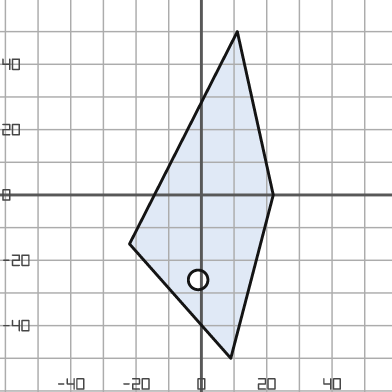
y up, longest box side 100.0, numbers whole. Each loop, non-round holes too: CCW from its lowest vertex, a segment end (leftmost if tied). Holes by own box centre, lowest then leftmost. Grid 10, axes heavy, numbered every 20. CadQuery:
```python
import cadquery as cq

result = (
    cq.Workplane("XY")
    .moveTo(9.0, -50.0)
    .lineTo(22.0, 0.0)
    .lineTo(11.0, 50.0)
    .lineTo(-22.0, -15.0)
    .close()
    .moveTo(-1.0, -26.0)
    .circle(3.0)
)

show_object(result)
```